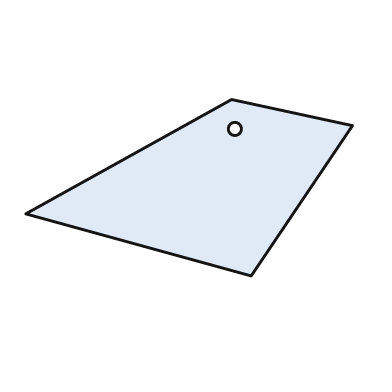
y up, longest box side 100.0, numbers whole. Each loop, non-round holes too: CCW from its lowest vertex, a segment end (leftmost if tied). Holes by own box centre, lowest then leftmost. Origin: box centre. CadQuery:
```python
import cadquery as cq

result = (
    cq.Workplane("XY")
    .moveTo(19.0, -27.0)
    .lineTo(50.0, 19.0)
    .lineTo(13.0, 27.0)
    .lineTo(-50.0, -8.0)
    .close()
    .moveTo(14.0, 18.0)
    .circle(2.0)
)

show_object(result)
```